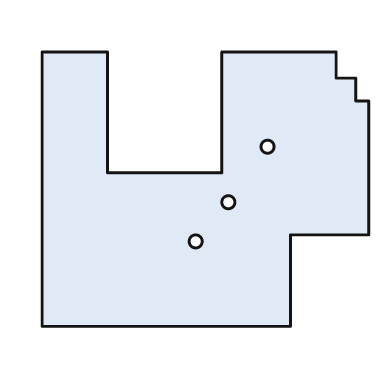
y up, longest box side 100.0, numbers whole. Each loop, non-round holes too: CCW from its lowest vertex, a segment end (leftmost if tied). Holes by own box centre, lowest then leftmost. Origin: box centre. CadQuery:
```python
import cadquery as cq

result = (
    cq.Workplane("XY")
    .moveTo(-50.0, -42.0)
    .lineTo(26.0, -42.0)
    .lineTo(26.0, -14.0)
    .lineTo(50.0, -14.0)
    .lineTo(50.0, 27.0)
    .lineTo(46.0, 27.0)
    .lineTo(46.0, 34.0)
    .lineTo(40.0, 34.0)
    .lineTo(40.0, 42.0)
    .lineTo(5.0, 42.0)
    .lineTo(5.0, 5.0)
    .lineTo(-30.0, 5.0)
    .lineTo(-30.0, 42.0)
    .lineTo(-50.0, 42.0)
    .close()
    .moveTo(-3.0, -16.0)
    .circle(2.0)
    .moveTo(7.0, -4.0)
    .circle(2.0)
    .moveTo(19.0, 13.0)
    .circle(2.0)
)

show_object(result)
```